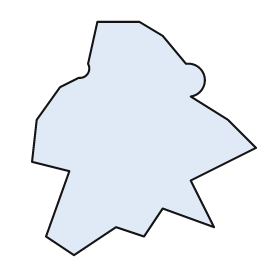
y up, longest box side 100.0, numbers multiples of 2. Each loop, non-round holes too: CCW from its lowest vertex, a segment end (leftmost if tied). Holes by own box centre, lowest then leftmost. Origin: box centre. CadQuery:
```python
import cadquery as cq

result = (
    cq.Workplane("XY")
    .moveTo(-30.0, -50.0)
    .lineTo(-12.0, -38.0)
    .lineTo(0.0, -42.0)
    .lineTo(8.0, -30.0)
    .lineTo(30.0, -38.0)
    .lineTo(20.0, -18.0)
    .lineTo(48.0, -4.0)
    .lineTo(36.0, 8.0)
    .lineTo(20.0, 18.0)
    .threePointArc((26.0, 26.0), (18.0, 32.0))
    .lineTo(8.0, 44.0)
    .lineTo(-2.0, 50.0)
    .lineTo(-20.0, 50.0)
    .lineTo(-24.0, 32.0)
    .threePointArc((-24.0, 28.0), (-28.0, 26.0))
    .lineTo(-36.0, 22.0)
    .lineTo(-46.0, 8.0)
    .lineTo(-48.0, -10.0)
    .lineTo(-32.0, -14.0)
    .lineTo(-42.0, -42.0)
    .close()
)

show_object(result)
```